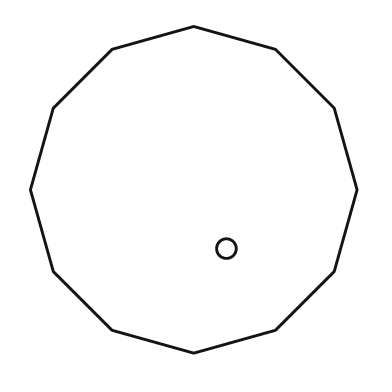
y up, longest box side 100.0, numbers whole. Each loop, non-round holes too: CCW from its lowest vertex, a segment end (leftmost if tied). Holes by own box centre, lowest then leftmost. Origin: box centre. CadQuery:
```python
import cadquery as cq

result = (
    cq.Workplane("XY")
    .moveTo(0.0, -50.0)
    .lineTo(25.0, -43.0)
    .lineTo(43.0, -25.0)
    .lineTo(50.0, 0.0)
    .lineTo(43.0, 25.0)
    .lineTo(25.0, 43.0)
    .lineTo(0.0, 50.0)
    .lineTo(-25.0, 43.0)
    .lineTo(-43.0, 25.0)
    .lineTo(-50.0, 0.0)
    .lineTo(-43.0, -25.0)
    .lineTo(-25.0, -43.0)
    .close()
    .moveTo(10.0, -18.0)
    .circle(3.0)
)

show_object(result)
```